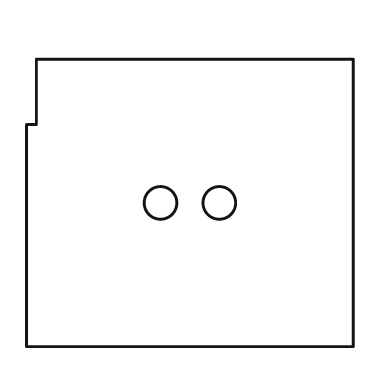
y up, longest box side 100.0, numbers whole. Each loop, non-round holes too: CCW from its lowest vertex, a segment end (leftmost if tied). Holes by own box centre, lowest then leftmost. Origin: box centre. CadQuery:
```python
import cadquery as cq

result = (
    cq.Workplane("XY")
    .moveTo(-50.0, -44.0)
    .lineTo(50.0, -44.0)
    .lineTo(50.0, 44.0)
    .lineTo(-47.0, 44.0)
    .lineTo(-47.0, 24.0)
    .lineTo(-50.0, 24.0)
    .close()
    .moveTo(-9.0, 0.0)
    .circle(5.0)
    .moveTo(9.0, 0.0)
    .circle(5.0)
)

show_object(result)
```